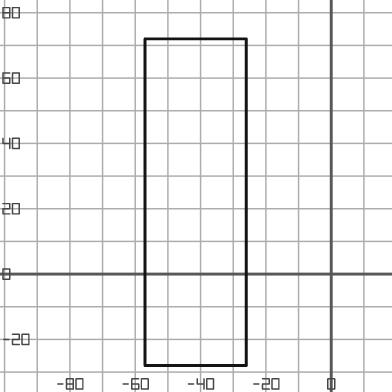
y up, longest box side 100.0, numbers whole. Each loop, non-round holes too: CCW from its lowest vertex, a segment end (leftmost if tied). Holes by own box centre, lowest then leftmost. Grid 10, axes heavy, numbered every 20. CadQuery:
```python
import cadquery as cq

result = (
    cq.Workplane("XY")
    .moveTo(-57.0, -28.0)
    .lineTo(-26.0, -28.0)
    .lineTo(-26.0, 72.0)
    .lineTo(-57.0, 72.0)
    .close()
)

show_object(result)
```